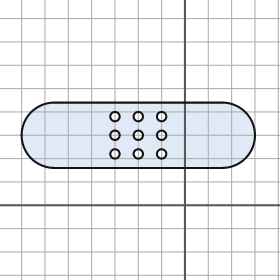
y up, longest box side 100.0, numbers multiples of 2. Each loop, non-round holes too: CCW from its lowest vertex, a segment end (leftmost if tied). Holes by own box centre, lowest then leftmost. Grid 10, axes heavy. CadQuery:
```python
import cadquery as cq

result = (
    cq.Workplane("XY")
    .moveTo(-56.0, 16.0)
    .lineTo(16.0, 16.0)
    .threePointArc((30.0, 30.0), (16.0, 44.0))
    .lineTo(-56.0, 44.0)
    .threePointArc((-70.0, 30.0), (-56.0, 16.0))
    .close()
    .moveTo(-30.0, 22.0)
    .circle(2.0)
    .moveTo(-20.0, 22.0)
    .circle(2.0)
    .moveTo(-10.0, 22.0)
    .circle(2.0)
    .moveTo(-30.0, 30.0)
    .circle(2.0)
    .moveTo(-20.0, 30.0)
    .circle(2.0)
    .moveTo(-10.0, 30.0)
    .circle(2.0)
    .moveTo(-30.0, 38.0)
    .circle(2.0)
    .moveTo(-20.0, 38.0)
    .circle(2.0)
    .moveTo(-10.0, 38.0)
    .circle(2.0)
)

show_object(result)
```